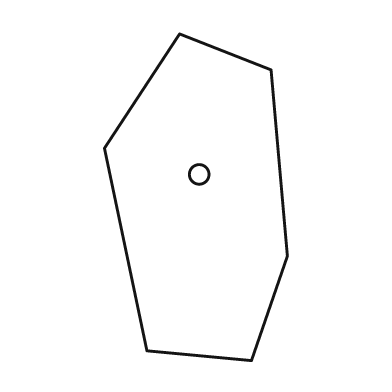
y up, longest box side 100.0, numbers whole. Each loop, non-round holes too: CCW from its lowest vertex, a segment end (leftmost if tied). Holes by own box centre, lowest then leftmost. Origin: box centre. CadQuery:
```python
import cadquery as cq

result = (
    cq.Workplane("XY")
    .moveTo(17.0, -50.0)
    .lineTo(28.0, -18.0)
    .lineTo(23.0, 39.0)
    .lineTo(-5.0, 50.0)
    .lineTo(-28.0, 15.0)
    .lineTo(-15.0, -47.0)
    .close()
    .moveTo(1.0, 7.0)
    .circle(3.0)
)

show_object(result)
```